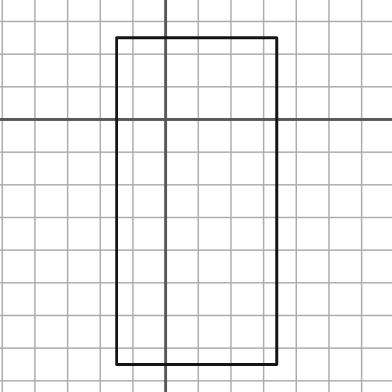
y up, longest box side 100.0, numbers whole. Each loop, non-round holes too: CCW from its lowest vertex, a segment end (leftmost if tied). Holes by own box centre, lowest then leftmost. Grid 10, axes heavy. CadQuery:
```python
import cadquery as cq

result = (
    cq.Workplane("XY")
    .moveTo(-15.0, -75.0)
    .lineTo(34.0, -75.0)
    .lineTo(34.0, 25.0)
    .lineTo(-15.0, 25.0)
    .close()
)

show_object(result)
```